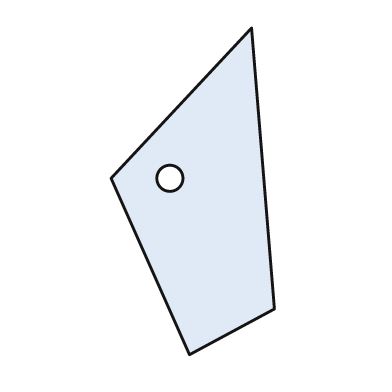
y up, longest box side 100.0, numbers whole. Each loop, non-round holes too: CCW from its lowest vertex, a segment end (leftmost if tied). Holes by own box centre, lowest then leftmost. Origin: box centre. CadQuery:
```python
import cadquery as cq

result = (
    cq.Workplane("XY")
    .moveTo(-1.0, -50.0)
    .lineTo(25.0, -36.0)
    .lineTo(18.0, 50.0)
    .lineTo(-25.0, 4.0)
    .close()
    .moveTo(-7.0, 4.0)
    .circle(4.0)
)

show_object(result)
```